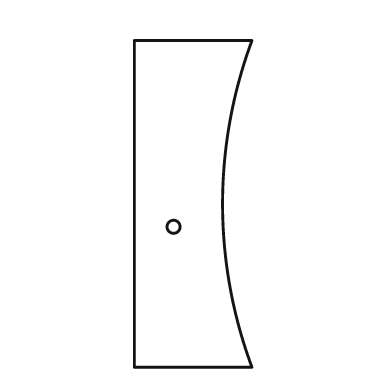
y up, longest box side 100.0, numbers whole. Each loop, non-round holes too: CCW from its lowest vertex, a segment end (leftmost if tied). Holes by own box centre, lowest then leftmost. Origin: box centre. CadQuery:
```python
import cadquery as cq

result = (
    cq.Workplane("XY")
    .moveTo(-18.0, -50.0)
    .lineTo(18.0, -50.0)
    .threePointArc((9.0, 0.0), (18.0, 50.0))
    .lineTo(-18.0, 50.0)
    .close()
    .moveTo(-6.0, -7.0)
    .circle(2.0)
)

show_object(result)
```